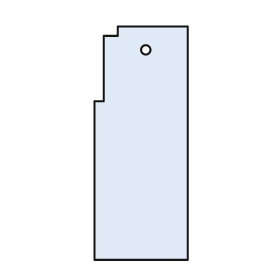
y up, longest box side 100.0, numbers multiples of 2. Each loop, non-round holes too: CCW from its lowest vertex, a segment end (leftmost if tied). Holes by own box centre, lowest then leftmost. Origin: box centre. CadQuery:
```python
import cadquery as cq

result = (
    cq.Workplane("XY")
    .moveTo(-20.0, -50.0)
    .lineTo(20.0, -50.0)
    .lineTo(20.0, 50.0)
    .lineTo(-10.0, 50.0)
    .lineTo(-10.0, 46.0)
    .lineTo(-16.0, 46.0)
    .lineTo(-16.0, 18.0)
    .lineTo(-20.0, 18.0)
    .close()
    .moveTo(2.0, 40.0)
    .circle(2.0)
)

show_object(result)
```